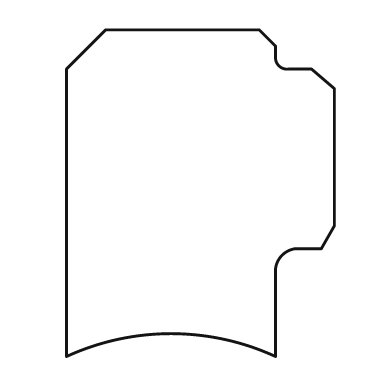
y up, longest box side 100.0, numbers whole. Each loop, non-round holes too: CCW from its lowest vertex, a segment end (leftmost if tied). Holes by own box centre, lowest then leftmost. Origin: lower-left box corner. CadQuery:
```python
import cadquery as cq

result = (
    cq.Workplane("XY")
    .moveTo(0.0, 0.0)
    .threePointArc((32.0, 7.0), (64.0, 0.0))
    .lineTo(64.0, 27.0)
    .threePointArc((66.0, 31.0), (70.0, 33.0))
    .lineTo(78.0, 33.0)
    .lineTo(82.0, 40.0)
    .lineTo(82.0, 82.0)
    .lineTo(75.0, 88.0)
    .lineTo(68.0, 88.0)
    .threePointArc((65.0, 89.0), (64.0, 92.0))
    .lineTo(64.0, 95.0)
    .lineTo(59.0, 100.0)
    .lineTo(12.0, 100.0)
    .lineTo(0.0, 88.0)
    .close()
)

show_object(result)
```